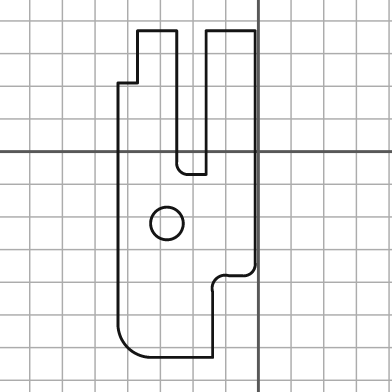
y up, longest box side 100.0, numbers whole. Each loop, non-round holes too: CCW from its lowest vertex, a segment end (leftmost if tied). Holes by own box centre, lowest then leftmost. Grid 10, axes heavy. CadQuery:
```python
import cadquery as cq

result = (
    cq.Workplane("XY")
    .moveTo(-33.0, -63.0)
    .lineTo(-14.0, -63.0)
    .lineTo(-14.0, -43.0)
    .threePointArc((-13.0, -39.0), (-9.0, -38.0))
    .lineTo(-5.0, -38.0)
    .threePointArc((-2.0, -37.0), (-1.0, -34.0))
    .lineTo(-1.0, 37.0)
    .lineTo(-16.0, 37.0)
    .lineTo(-16.0, -7.0)
    .lineTo(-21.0, -7.0)
    .threePointArc((-24.0, -6.0), (-25.0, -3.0))
    .lineTo(-25.0, 37.0)
    .lineTo(-37.0, 37.0)
    .lineTo(-37.0, 21.0)
    .lineTo(-43.0, 21.0)
    .lineTo(-43.0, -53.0)
    .threePointArc((-40.0, -60.0), (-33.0, -63.0))
    .close()
    .moveTo(-28.0, -22.0)
    .circle(5.0)
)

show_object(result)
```